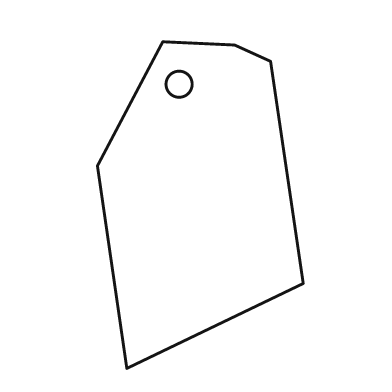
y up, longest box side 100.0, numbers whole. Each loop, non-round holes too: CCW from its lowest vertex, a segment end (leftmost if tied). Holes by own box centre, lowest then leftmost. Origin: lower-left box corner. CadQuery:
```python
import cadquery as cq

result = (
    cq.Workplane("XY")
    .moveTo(9.0, 0.0)
    .lineTo(63.0, 26.0)
    .lineTo(53.0, 94.0)
    .lineTo(42.0, 99.0)
    .lineTo(20.0, 100.0)
    .lineTo(0.0, 62.0)
    .close()
    .moveTo(25.0, 87.0)
    .circle(4.0)
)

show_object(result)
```